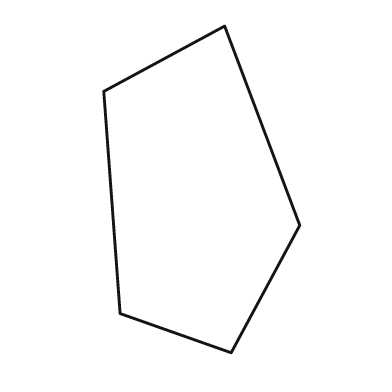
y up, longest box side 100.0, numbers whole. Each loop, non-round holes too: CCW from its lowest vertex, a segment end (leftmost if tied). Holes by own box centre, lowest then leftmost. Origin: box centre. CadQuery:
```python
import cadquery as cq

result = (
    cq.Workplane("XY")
    .moveTo(9.0, -50.0)
    .lineTo(30.0, -11.0)
    .lineTo(7.0, 50.0)
    .lineTo(-30.0, 30.0)
    .lineTo(-25.0, -38.0)
    .close()
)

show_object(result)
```